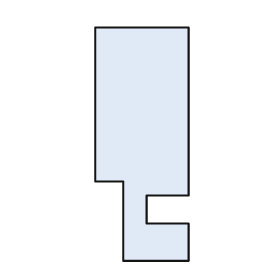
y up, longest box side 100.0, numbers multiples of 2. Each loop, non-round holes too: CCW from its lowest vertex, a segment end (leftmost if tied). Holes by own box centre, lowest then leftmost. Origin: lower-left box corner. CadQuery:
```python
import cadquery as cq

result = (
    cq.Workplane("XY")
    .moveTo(12.0, 0.0)
    .lineTo(40.0, 0.0)
    .lineTo(40.0, 16.0)
    .lineTo(22.0, 16.0)
    .lineTo(22.0, 28.0)
    .lineTo(40.0, 28.0)
    .lineTo(40.0, 100.0)
    .lineTo(0.0, 100.0)
    .lineTo(0.0, 34.0)
    .lineTo(12.0, 34.0)
    .close()
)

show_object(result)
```